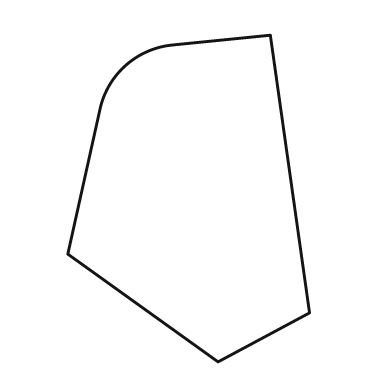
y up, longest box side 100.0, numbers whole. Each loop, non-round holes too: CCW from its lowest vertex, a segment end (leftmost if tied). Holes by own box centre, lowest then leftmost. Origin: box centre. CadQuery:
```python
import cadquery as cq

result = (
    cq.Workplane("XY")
    .moveTo(9.0, -50.0)
    .lineTo(37.0, -35.0)
    .lineTo(25.0, 50.0)
    .lineTo(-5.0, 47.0)
    .threePointArc((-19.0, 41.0), (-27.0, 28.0))
    .lineTo(-37.0, -17.0)
    .close()
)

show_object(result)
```